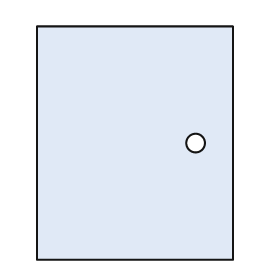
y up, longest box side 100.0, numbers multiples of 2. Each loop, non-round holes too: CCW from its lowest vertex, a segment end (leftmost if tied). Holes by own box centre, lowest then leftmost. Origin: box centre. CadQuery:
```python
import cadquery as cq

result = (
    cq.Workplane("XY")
    .moveTo(-42.0, -50.0)
    .lineTo(42.0, -50.0)
    .lineTo(42.0, 50.0)
    .lineTo(-42.0, 50.0)
    .close()
    .moveTo(26.0, 0.0)
    .circle(4.0)
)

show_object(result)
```